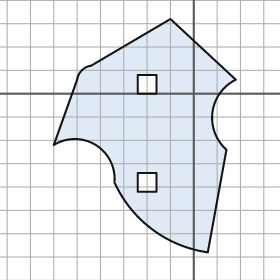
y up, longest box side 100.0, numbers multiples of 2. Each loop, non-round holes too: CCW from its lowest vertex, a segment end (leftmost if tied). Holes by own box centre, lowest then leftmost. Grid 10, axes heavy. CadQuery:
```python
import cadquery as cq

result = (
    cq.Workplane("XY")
    .moveTo(6.0, -68.0)
    .lineTo(14.0, -24.0)
    .threePointArc((8.0, -8.0), (18.0, 6.0))
    .lineTo(-10.0, 32.0)
    .lineTo(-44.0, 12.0)
    .threePointArc((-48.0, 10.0), (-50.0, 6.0))
    .lineTo(-60.0, -22.0)
    .threePointArc((-42.0, -22.0), (-34.0, -38.0))
    .threePointArc((-18.0, -58.0), (6.0, -68.0))
    .close()
    .moveTo(-24.0, -42.0)
    .lineTo(-16.0, -42.0)
    .lineTo(-16.0, -34.0)
    .lineTo(-24.0, -34.0)
    .close()
    .moveTo(-24.0, 0.0)
    .lineTo(-16.0, 0.0)
    .lineTo(-16.0, 8.0)
    .lineTo(-24.0, 8.0)
    .close()
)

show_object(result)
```